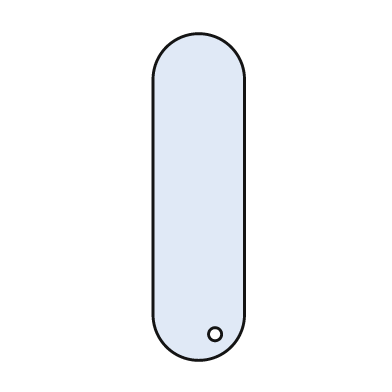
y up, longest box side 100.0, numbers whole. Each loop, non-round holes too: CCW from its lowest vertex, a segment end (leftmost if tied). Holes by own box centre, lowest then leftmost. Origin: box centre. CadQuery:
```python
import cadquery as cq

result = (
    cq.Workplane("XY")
    .moveTo(-14.0, -36.0)
    .threePointArc((0.0, -50.0), (14.0, -36.0))
    .lineTo(14.0, 36.0)
    .threePointArc((0.0, 50.0), (-14.0, 36.0))
    .close()
    .moveTo(5.0, -42.0)
    .circle(2.0)
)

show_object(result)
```